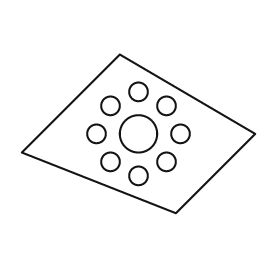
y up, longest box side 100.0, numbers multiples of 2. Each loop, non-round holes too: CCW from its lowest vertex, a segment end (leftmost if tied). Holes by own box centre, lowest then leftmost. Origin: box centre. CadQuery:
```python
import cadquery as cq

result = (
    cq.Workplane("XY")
    .moveTo(16.0, -34.0)
    .lineTo(50.0, 0.0)
    .lineTo(-8.0, 34.0)
    .lineTo(-50.0, -8.0)
    .close()
    .moveTo(0.0, -18.0)
    .circle(4.0)
    .moveTo(-12.0, -12.0)
    .circle(4.0)
    .moveTo(12.0, -12.0)
    .circle(4.0)
    .moveTo(-18.0, 0.0)
    .circle(4.0)
    .moveTo(0.0, 0.0)
    .circle(8.0)
    .moveTo(18.0, 0.0)
    .circle(4.0)
    .moveTo(-12.0, 12.0)
    .circle(4.0)
    .moveTo(12.0, 12.0)
    .circle(4.0)
    .moveTo(0.0, 18.0)
    .circle(4.0)
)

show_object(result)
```